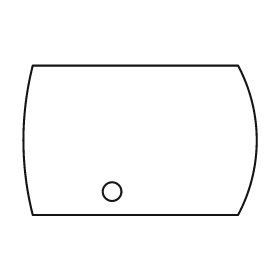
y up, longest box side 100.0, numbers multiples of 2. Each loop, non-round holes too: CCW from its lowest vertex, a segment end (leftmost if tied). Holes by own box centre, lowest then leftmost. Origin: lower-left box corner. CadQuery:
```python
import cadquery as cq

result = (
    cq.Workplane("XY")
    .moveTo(4.0, 0.0)
    .lineTo(92.0, 0.0)
    .threePointArc((100.0, 32.0), (92.0, 64.0))
    .lineTo(4.0, 64.0)
    .threePointArc((0.0, 32.0), (4.0, 0.0))
    .close()
    .moveTo(38.0, 10.0)
    .circle(4.0)
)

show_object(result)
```